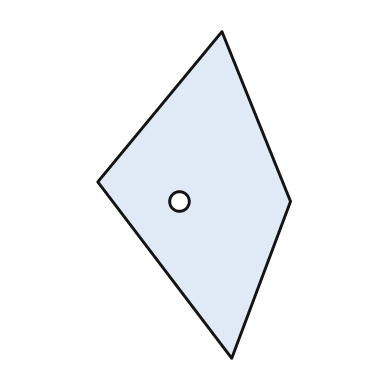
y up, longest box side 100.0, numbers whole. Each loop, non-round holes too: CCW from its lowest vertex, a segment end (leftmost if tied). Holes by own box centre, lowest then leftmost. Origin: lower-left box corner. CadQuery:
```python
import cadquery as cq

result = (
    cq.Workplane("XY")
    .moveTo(41.0, 0.0)
    .lineTo(59.0, 48.0)
    .lineTo(38.0, 100.0)
    .lineTo(0.0, 54.0)
    .close()
    .moveTo(25.0, 48.0)
    .circle(3.0)
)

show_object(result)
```